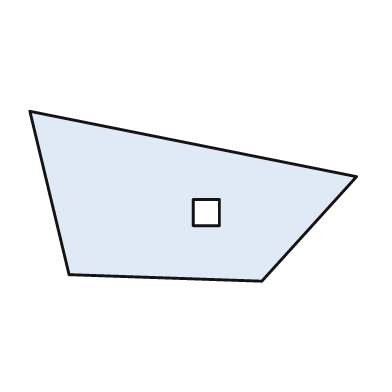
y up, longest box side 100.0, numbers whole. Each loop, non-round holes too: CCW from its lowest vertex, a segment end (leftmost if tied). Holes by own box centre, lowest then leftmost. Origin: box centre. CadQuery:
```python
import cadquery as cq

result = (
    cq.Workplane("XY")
    .moveTo(21.0, -26.0)
    .lineTo(50.0, 6.0)
    .lineTo(-50.0, 26.0)
    .lineTo(-38.0, -24.0)
    .close()
    .moveTo(0.0, -9.0)
    .lineTo(8.0, -9.0)
    .lineTo(8.0, -1.0)
    .lineTo(0.0, -1.0)
    .close()
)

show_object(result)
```